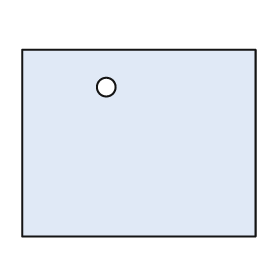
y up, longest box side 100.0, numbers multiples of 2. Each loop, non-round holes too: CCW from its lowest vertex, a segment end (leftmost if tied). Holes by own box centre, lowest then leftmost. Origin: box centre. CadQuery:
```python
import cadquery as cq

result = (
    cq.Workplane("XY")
    .moveTo(-50.0, -40.0)
    .lineTo(50.0, -40.0)
    .lineTo(50.0, 40.0)
    .lineTo(-50.0, 40.0)
    .close()
    .moveTo(-14.0, 24.0)
    .circle(4.0)
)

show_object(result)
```